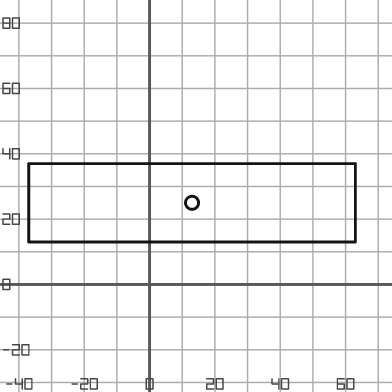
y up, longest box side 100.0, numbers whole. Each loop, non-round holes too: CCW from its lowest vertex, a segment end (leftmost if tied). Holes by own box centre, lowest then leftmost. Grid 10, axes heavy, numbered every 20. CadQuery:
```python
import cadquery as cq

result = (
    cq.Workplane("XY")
    .moveTo(-37.0, 13.0)
    .lineTo(63.0, 13.0)
    .lineTo(63.0, 37.0)
    .lineTo(-37.0, 37.0)
    .close()
    .moveTo(13.0, 25.0)
    .circle(2.0)
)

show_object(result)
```